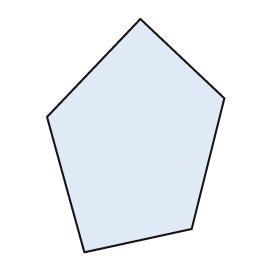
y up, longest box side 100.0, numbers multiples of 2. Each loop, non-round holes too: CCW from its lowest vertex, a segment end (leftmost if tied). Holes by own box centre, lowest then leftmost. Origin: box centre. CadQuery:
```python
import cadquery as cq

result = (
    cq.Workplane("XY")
    .moveTo(-22.0, -50.0)
    .lineTo(24.0, -40.0)
    .lineTo(38.0, 16.0)
    .lineTo(2.0, 50.0)
    .lineTo(-38.0, 8.0)
    .close()
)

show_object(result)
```